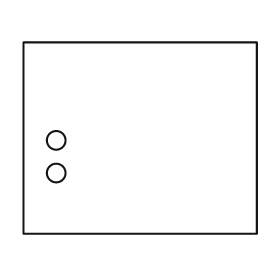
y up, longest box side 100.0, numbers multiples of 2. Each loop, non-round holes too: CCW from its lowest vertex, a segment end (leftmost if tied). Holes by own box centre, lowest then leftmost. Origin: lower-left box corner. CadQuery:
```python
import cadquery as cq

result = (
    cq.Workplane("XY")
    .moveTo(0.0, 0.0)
    .lineTo(100.0, 0.0)
    .lineTo(100.0, 82.0)
    .lineTo(0.0, 82.0)
    .close()
    .moveTo(14.0, 26.0)
    .circle(4.0)
    .moveTo(14.0, 40.0)
    .circle(4.0)
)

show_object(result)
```